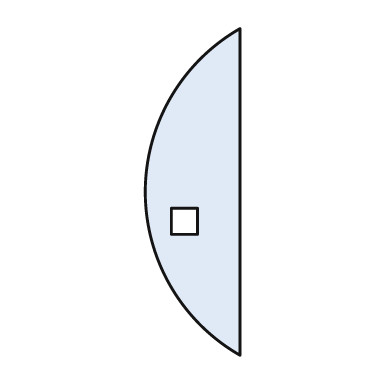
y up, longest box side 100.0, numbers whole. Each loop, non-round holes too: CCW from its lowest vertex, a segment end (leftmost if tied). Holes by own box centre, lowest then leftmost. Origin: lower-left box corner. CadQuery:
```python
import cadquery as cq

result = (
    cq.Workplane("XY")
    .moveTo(29.0, 0.0)
    .lineTo(29.0, 100.0)
    .threePointArc((0.0, 50.0), (29.0, 0.0))
    .close()
    .moveTo(8.0, 37.0)
    .lineTo(16.0, 37.0)
    .lineTo(16.0, 45.0)
    .lineTo(8.0, 45.0)
    .close()
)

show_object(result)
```